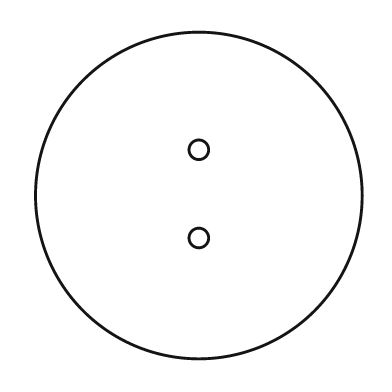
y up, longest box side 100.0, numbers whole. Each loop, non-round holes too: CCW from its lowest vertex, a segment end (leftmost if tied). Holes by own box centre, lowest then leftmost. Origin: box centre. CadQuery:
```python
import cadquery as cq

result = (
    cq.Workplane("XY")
    .moveTo(0.0, 0.0)
    .circle(50.0)
    .moveTo(0.0, -13.0)
    .circle(3.0)
    .moveTo(0.0, 14.0)
    .circle(3.0)
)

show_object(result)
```